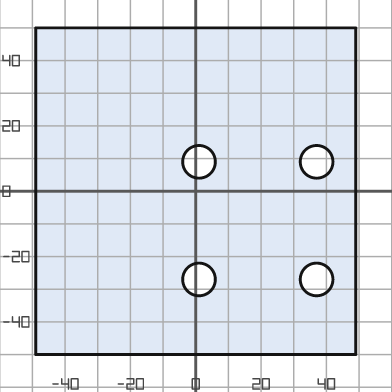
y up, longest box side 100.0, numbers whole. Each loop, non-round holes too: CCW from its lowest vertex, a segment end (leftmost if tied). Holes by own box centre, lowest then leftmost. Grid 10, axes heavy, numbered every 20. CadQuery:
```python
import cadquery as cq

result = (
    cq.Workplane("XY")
    .moveTo(-49.0, -50.0)
    .lineTo(49.0, -50.0)
    .lineTo(49.0, 50.0)
    .lineTo(-49.0, 50.0)
    .close()
    .moveTo(1.0, -27.0)
    .circle(5.0)
    .moveTo(37.0, -27.0)
    .circle(5.0)
    .moveTo(1.0, 9.0)
    .circle(5.0)
    .moveTo(37.0, 9.0)
    .circle(5.0)
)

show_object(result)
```